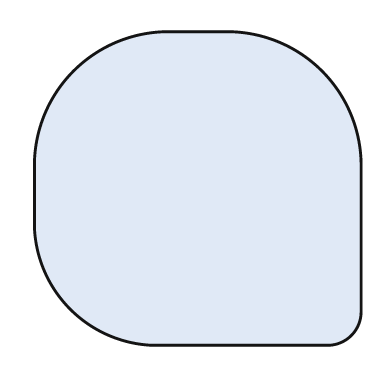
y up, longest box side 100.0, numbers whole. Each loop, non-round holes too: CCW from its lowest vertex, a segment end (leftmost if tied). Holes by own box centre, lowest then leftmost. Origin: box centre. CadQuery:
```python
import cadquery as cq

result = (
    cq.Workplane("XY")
    .moveTo(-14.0, -48.0)
    .lineTo(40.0, -48.0)
    .threePointArc((47.0, -45.0), (50.0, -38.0))
    .lineTo(50.0, 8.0)
    .threePointArc((38.0, 36.0), (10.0, 48.0))
    .lineTo(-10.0, 48.0)
    .threePointArc((-38.0, 36.0), (-50.0, 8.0))
    .lineTo(-50.0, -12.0)
    .threePointArc((-39.0, -37.0), (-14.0, -48.0))
    .close()
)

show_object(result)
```